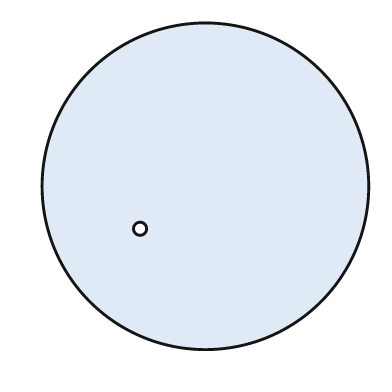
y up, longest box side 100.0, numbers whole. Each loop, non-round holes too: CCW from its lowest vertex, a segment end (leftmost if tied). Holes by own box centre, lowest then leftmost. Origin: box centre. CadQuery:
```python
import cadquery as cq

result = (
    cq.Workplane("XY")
    .moveTo(0.0, 0.0)
    .circle(50.0)
    .moveTo(-20.0, -13.0)
    .circle(2.0)
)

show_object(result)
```